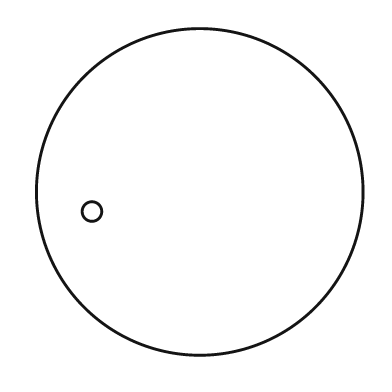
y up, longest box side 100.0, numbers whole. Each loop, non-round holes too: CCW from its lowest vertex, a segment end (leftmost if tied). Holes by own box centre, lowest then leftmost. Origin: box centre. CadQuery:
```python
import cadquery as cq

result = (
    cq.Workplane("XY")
    .moveTo(0.0, 0.0)
    .circle(50.0)
    .moveTo(-33.0, -6.0)
    .circle(3.0)
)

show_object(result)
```